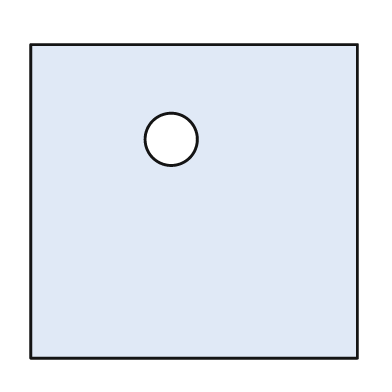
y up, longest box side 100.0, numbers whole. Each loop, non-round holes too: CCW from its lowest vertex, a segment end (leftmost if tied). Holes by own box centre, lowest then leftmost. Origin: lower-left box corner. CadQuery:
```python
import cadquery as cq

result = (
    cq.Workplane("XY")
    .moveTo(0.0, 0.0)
    .lineTo(100.0, 0.0)
    .lineTo(100.0, 96.0)
    .lineTo(0.0, 96.0)
    .close()
    .moveTo(43.0, 67.0)
    .circle(8.0)
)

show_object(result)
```